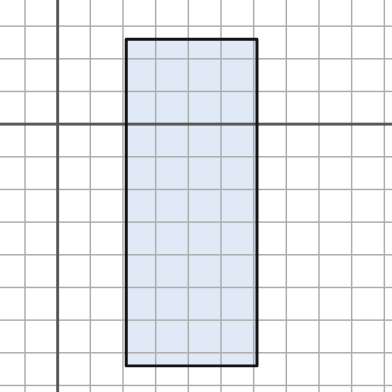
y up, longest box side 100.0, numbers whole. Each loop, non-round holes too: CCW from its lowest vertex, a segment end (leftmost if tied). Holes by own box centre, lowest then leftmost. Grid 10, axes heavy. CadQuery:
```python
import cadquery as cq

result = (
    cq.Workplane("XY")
    .moveTo(21.0, -74.0)
    .lineTo(61.0, -74.0)
    .lineTo(61.0, 26.0)
    .lineTo(21.0, 26.0)
    .close()
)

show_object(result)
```